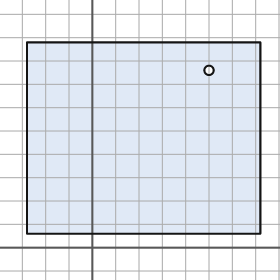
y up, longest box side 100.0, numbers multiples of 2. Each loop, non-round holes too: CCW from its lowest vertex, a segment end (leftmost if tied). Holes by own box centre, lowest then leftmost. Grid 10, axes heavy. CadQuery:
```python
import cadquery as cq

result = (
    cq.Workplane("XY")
    .moveTo(-28.0, 6.0)
    .lineTo(72.0, 6.0)
    .lineTo(72.0, 88.0)
    .lineTo(-28.0, 88.0)
    .close()
    .moveTo(50.0, 76.0)
    .circle(2.0)
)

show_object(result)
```